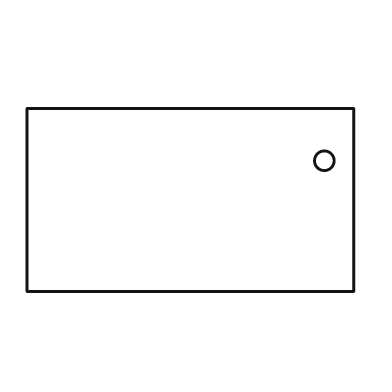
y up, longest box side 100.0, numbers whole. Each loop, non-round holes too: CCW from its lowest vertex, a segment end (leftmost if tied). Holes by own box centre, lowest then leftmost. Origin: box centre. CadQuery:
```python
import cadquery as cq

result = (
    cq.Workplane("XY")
    .moveTo(-50.0, -28.0)
    .lineTo(50.0, -28.0)
    .lineTo(50.0, 28.0)
    .lineTo(-50.0, 28.0)
    .close()
    .moveTo(41.0, 12.0)
    .circle(3.0)
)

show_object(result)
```